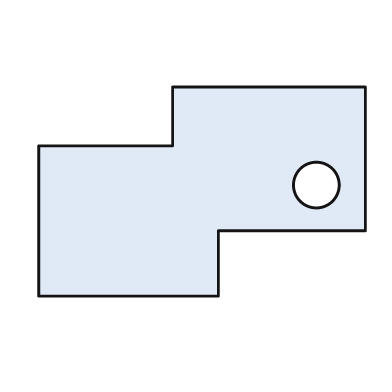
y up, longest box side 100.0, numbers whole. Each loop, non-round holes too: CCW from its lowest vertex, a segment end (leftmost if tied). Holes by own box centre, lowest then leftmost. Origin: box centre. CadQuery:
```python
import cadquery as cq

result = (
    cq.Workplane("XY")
    .moveTo(-50.0, -32.0)
    .lineTo(5.0, -32.0)
    .lineTo(5.0, -12.0)
    .lineTo(50.0, -12.0)
    .lineTo(50.0, 32.0)
    .lineTo(-9.0, 32.0)
    .lineTo(-9.0, 14.0)
    .lineTo(-50.0, 14.0)
    .close()
    .moveTo(35.0, 2.0)
    .circle(7.0)
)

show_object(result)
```